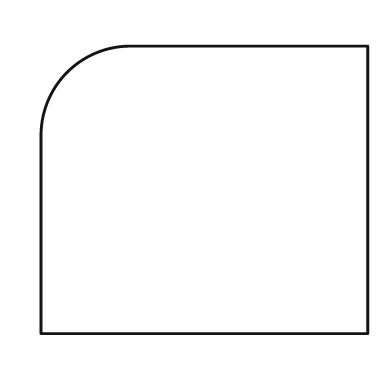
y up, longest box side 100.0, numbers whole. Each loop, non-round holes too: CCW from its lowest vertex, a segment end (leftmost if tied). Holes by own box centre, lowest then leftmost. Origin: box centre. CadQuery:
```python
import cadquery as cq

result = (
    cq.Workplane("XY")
    .moveTo(-50.0, -44.0)
    .lineTo(50.0, -44.0)
    .lineTo(50.0, 44.0)
    .lineTo(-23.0, 44.0)
    .threePointArc((-42.0, 36.0), (-50.0, 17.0))
    .close()
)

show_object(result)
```